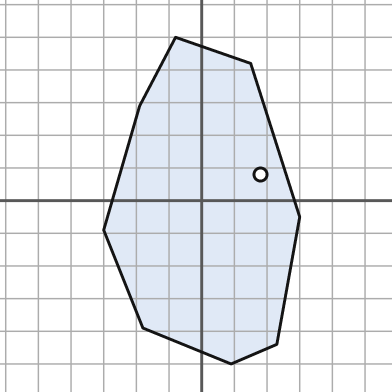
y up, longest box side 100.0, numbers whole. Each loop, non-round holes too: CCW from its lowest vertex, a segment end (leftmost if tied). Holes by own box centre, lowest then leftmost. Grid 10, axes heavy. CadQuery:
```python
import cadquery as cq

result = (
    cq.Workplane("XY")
    .moveTo(9.0, -50.0)
    .lineTo(23.0, -44.0)
    .lineTo(30.0, -5.0)
    .lineTo(15.0, 42.0)
    .lineTo(-8.0, 50.0)
    .lineTo(-19.0, 29.0)
    .lineTo(-30.0, -9.0)
    .lineTo(-18.0, -39.0)
    .close()
    .moveTo(18.0, 8.0)
    .circle(2.0)
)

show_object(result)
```